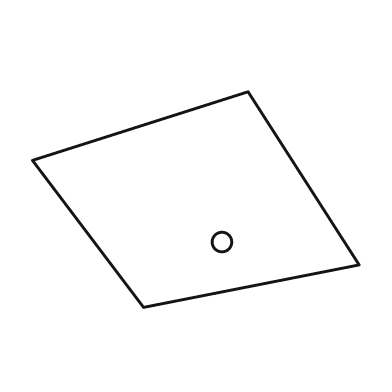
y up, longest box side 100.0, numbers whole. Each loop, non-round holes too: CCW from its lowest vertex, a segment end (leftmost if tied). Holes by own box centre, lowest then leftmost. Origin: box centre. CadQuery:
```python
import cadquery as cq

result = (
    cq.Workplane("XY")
    .moveTo(-16.0, -33.0)
    .lineTo(50.0, -20.0)
    .lineTo(16.0, 33.0)
    .lineTo(-50.0, 12.0)
    .close()
    .moveTo(8.0, -13.0)
    .circle(3.0)
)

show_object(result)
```